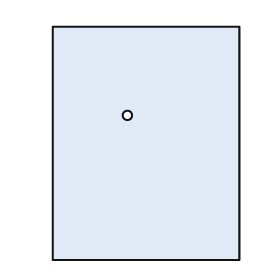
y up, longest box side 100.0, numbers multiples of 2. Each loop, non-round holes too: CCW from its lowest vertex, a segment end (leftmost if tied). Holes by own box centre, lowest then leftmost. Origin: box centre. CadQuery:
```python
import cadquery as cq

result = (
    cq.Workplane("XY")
    .moveTo(-40.0, -50.0)
    .lineTo(40.0, -50.0)
    .lineTo(40.0, 50.0)
    .lineTo(-40.0, 50.0)
    .close()
    .moveTo(-8.0, 12.0)
    .circle(2.0)
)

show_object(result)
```